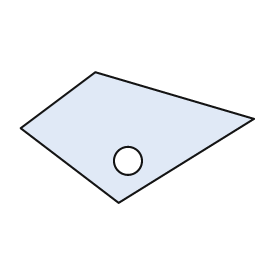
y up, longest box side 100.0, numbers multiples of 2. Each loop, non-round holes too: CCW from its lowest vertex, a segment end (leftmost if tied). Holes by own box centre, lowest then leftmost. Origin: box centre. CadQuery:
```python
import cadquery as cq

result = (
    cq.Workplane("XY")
    .moveTo(-8.0, -28.0)
    .lineTo(50.0, 8.0)
    .lineTo(-18.0, 28.0)
    .lineTo(-50.0, 4.0)
    .close()
    .moveTo(-4.0, -10.0)
    .circle(6.0)
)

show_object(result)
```